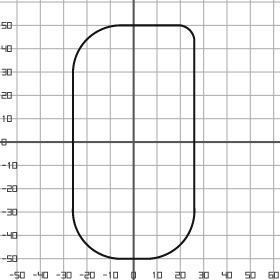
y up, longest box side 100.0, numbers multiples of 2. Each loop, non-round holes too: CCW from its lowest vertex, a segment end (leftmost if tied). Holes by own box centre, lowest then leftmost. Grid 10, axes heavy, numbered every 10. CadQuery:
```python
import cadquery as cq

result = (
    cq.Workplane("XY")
    .moveTo(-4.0, -50.0)
    .lineTo(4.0, -50.0)
    .threePointArc((20.0, -44.0), (26.0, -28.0))
    .lineTo(26.0, 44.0)
    .threePointArc((24.0, 48.0), (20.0, 50.0))
    .lineTo(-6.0, 50.0)
    .threePointArc((-20.0, 44.0), (-26.0, 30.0))
    .lineTo(-26.0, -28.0)
    .threePointArc((-20.0, -44.0), (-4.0, -50.0))
    .close()
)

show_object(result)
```